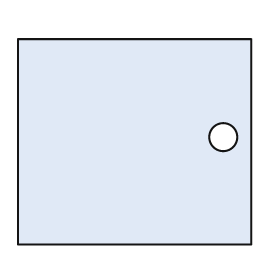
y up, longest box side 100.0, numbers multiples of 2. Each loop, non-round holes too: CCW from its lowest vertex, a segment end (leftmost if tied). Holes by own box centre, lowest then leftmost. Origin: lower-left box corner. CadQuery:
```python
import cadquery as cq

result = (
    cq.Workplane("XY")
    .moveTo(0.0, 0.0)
    .lineTo(100.0, 0.0)
    .lineTo(100.0, 88.0)
    .lineTo(0.0, 88.0)
    .close()
    .moveTo(88.0, 46.0)
    .circle(6.0)
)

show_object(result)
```